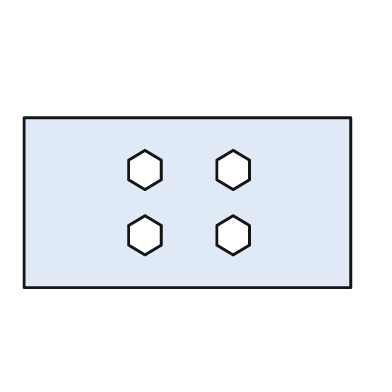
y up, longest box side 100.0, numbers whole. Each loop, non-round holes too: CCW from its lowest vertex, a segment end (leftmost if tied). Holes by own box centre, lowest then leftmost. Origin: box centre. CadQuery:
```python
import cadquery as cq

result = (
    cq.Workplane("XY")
    .moveTo(-50.0, -26.0)
    .lineTo(50.0, -26.0)
    .lineTo(50.0, 26.0)
    .lineTo(-50.0, 26.0)
    .close()
    .moveTo(-13.0, -16.0)
    .lineTo(-8.0, -13.0)
    .lineTo(-8.0, -7.0)
    .lineTo(-13.0, -4.0)
    .lineTo(-18.0, -7.0)
    .lineTo(-18.0, -13.0)
    .close()
    .moveTo(14.0, -16.0)
    .lineTo(19.0, -13.0)
    .lineTo(19.0, -7.0)
    .lineTo(14.0, -4.0)
    .lineTo(9.0, -7.0)
    .lineTo(9.0, -13.0)
    .close()
    .moveTo(-13.0, 4.0)
    .lineTo(-8.0, 7.0)
    .lineTo(-8.0, 13.0)
    .lineTo(-13.0, 16.0)
    .lineTo(-18.0, 13.0)
    .lineTo(-18.0, 7.0)
    .close()
    .moveTo(14.0, 4.0)
    .lineTo(19.0, 7.0)
    .lineTo(19.0, 13.0)
    .lineTo(14.0, 16.0)
    .lineTo(9.0, 13.0)
    .lineTo(9.0, 7.0)
    .close()
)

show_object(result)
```